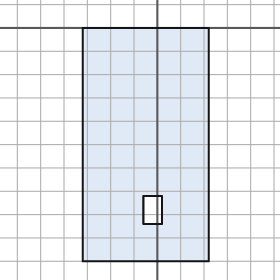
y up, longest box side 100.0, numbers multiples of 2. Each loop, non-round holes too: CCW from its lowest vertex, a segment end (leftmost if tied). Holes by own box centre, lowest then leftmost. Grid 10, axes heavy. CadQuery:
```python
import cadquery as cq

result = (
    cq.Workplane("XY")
    .moveTo(-32.0, -100.0)
    .lineTo(22.0, -100.0)
    .lineTo(22.0, 0.0)
    .lineTo(-32.0, 0.0)
    .close()
    .moveTo(-6.0, -84.0)
    .lineTo(2.0, -84.0)
    .lineTo(2.0, -72.0)
    .lineTo(-6.0, -72.0)
    .close()
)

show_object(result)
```